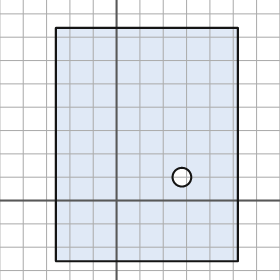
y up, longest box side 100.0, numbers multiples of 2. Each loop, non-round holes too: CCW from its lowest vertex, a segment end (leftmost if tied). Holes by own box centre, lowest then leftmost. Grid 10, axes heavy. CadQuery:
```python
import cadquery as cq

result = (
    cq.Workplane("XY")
    .moveTo(-26.0, -26.0)
    .lineTo(52.0, -26.0)
    .lineTo(52.0, 74.0)
    .lineTo(-26.0, 74.0)
    .close()
    .moveTo(28.0, 10.0)
    .circle(4.0)
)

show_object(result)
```